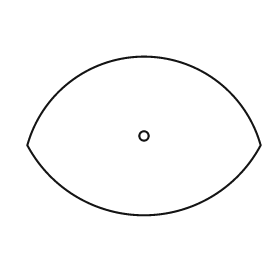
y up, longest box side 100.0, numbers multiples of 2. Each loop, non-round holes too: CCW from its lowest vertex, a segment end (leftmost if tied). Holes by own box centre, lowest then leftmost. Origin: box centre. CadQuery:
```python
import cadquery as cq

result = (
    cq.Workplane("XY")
    .moveTo(-50.0, -4.0)
    .threePointArc((0.0, -34.0), (50.0, -4.0))
    .threePointArc((0.0, 34.0), (-50.0, -4.0))
    .close()
    .moveTo(0.0, 0.0)
    .circle(2.0)
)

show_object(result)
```